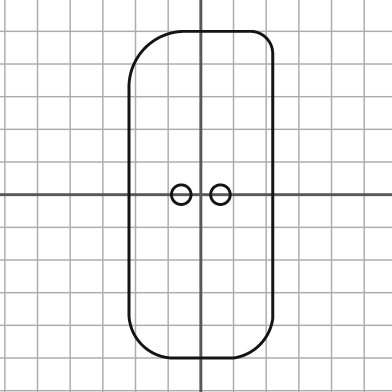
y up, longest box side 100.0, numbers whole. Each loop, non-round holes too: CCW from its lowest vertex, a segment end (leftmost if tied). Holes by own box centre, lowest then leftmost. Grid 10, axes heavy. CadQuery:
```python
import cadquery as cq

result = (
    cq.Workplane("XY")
    .moveTo(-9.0, -50.0)
    .lineTo(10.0, -50.0)
    .threePointArc((18.0, -46.0), (22.0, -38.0))
    .lineTo(22.0, 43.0)
    .threePointArc((20.0, 48.0), (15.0, 50.0))
    .lineTo(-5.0, 50.0)
    .threePointArc((-17.0, 45.0), (-22.0, 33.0))
    .lineTo(-22.0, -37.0)
    .threePointArc((-18.0, -46.0), (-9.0, -50.0))
    .close()
    .moveTo(-6.0, 0.0)
    .circle(3.0)
    .moveTo(6.0, 0.0)
    .circle(3.0)
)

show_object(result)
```